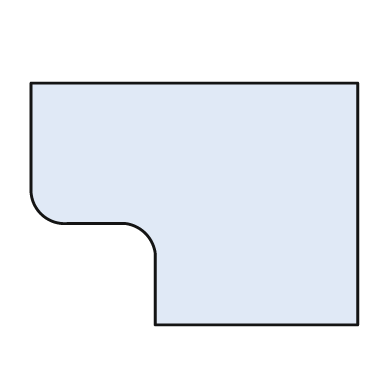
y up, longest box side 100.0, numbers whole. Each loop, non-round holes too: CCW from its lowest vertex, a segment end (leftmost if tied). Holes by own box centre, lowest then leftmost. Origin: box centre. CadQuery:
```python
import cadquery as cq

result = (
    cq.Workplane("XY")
    .moveTo(-12.0, -37.0)
    .lineTo(50.0, -37.0)
    .lineTo(50.0, 37.0)
    .lineTo(-50.0, 37.0)
    .lineTo(-50.0, 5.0)
    .threePointArc((-47.0, -3.0), (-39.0, -6.0))
    .lineTo(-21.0, -6.0)
    .threePointArc((-15.0, -9.0), (-12.0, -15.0))
    .close()
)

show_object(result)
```